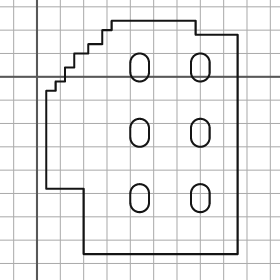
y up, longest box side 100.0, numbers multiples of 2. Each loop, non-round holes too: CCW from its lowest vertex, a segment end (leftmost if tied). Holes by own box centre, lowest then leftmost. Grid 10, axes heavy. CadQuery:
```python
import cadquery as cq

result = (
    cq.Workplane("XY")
    .moveTo(20.0, -76.0)
    .lineTo(86.0, -76.0)
    .lineTo(86.0, 18.0)
    .lineTo(68.0, 18.0)
    .lineTo(68.0, 24.0)
    .lineTo(32.0, 24.0)
    .lineTo(32.0, 20.0)
    .lineTo(28.0, 20.0)
    .lineTo(28.0, 14.0)
    .lineTo(22.0, 14.0)
    .lineTo(22.0, 10.0)
    .lineTo(16.0, 10.0)
    .lineTo(16.0, 4.0)
    .lineTo(12.0, 4.0)
    .lineTo(12.0, -2.0)
    .lineTo(8.0, -2.0)
    .lineTo(8.0, -6.0)
    .lineTo(4.0, -6.0)
    .lineTo(4.0, -48.0)
    .lineTo(20.0, -48.0)
    .close()
    .moveTo(40.0, -54.0)
    .threePointArc((44.0, -58.0), (48.0, -54.0))
    .lineTo(48.0, -50.0)
    .threePointArc((44.0, -46.0), (40.0, -50.0))
    .close()
    .moveTo(66.0, -54.0)
    .threePointArc((70.0, -58.0), (74.0, -54.0))
    .lineTo(74.0, -50.0)
    .threePointArc((70.0, -46.0), (66.0, -50.0))
    .close()
    .moveTo(40.0, -26.0)
    .threePointArc((44.0, -30.0), (48.0, -26.0))
    .lineTo(48.0, -22.0)
    .threePointArc((44.0, -18.0), (40.0, -22.0))
    .close()
    .moveTo(66.0, -26.0)
    .threePointArc((70.0, -30.0), (74.0, -26.0))
    .lineTo(74.0, -22.0)
    .threePointArc((70.0, -18.0), (66.0, -22.0))
    .close()
    .moveTo(40.0, 2.0)
    .threePointArc((44.0, -2.0), (48.0, 2.0))
    .lineTo(48.0, 6.0)
    .threePointArc((44.0, 10.0), (40.0, 6.0))
    .close()
    .moveTo(66.0, 2.0)
    .threePointArc((70.0, -2.0), (74.0, 2.0))
    .lineTo(74.0, 6.0)
    .threePointArc((70.0, 10.0), (66.0, 6.0))
    .close()
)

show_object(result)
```